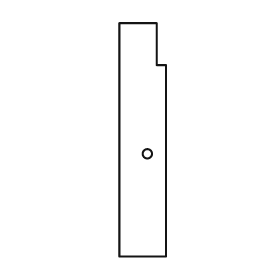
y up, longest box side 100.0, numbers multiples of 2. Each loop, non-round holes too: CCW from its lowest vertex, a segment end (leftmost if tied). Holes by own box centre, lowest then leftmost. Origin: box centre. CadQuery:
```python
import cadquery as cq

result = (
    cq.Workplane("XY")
    .moveTo(-10.0, -50.0)
    .lineTo(10.0, -50.0)
    .lineTo(10.0, 32.0)
    .lineTo(6.0, 32.0)
    .lineTo(6.0, 50.0)
    .lineTo(-10.0, 50.0)
    .close()
    .moveTo(2.0, -6.0)
    .circle(2.0)
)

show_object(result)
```